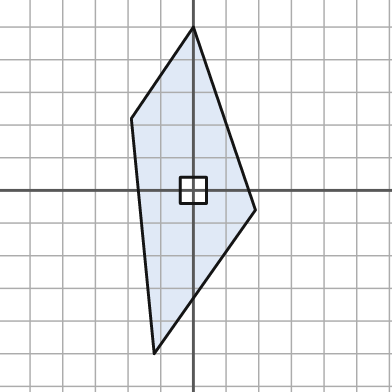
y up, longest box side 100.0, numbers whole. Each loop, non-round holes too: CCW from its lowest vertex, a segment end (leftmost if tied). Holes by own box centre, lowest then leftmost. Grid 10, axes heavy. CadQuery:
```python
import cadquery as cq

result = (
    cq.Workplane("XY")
    .moveTo(-12.0, -50.0)
    .lineTo(19.0, -6.0)
    .lineTo(0.0, 50.0)
    .lineTo(-19.0, 22.0)
    .close()
    .moveTo(-4.0, -4.0)
    .lineTo(4.0, -4.0)
    .lineTo(4.0, 4.0)
    .lineTo(-4.0, 4.0)
    .close()
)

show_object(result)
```